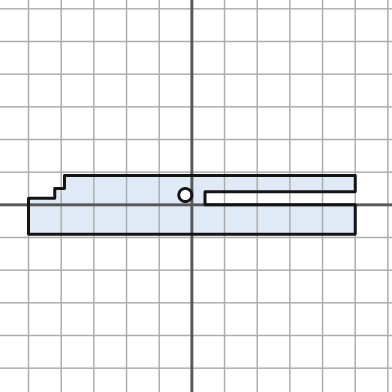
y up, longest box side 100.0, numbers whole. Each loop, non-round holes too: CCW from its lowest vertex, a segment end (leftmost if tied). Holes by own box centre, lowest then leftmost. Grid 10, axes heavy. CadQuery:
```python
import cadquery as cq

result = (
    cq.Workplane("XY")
    .moveTo(-50.0, -9.0)
    .lineTo(50.0, -9.0)
    .lineTo(50.0, 0.0)
    .lineTo(4.0, 0.0)
    .lineTo(4.0, 4.0)
    .lineTo(50.0, 4.0)
    .lineTo(50.0, 9.0)
    .lineTo(-39.0, 9.0)
    .lineTo(-39.0, 5.0)
    .lineTo(-42.0, 5.0)
    .lineTo(-42.0, 2.0)
    .lineTo(-50.0, 2.0)
    .close()
    .moveTo(-2.0, 3.0)
    .circle(2.0)
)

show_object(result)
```